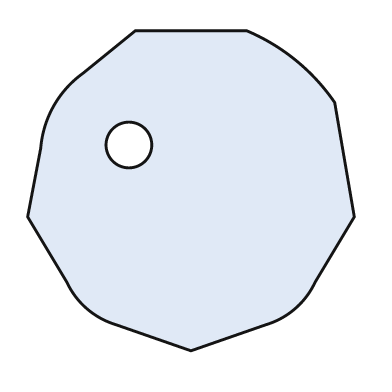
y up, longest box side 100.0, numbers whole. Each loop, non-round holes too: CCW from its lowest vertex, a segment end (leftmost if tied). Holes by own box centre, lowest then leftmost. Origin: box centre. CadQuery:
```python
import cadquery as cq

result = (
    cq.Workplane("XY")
    .moveTo(0.0, -49.0)
    .lineTo(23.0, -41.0)
    .threePointArc((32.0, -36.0), (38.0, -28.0))
    .lineTo(50.0, -8.0)
    .lineTo(44.0, 27.0)
    .threePointArc((32.0, 40.0), (17.0, 49.0))
    .lineTo(-17.0, 49.0)
    .lineTo(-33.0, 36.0)
    .threePointArc((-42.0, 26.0), (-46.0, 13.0))
    .lineTo(-50.0, -8.0)
    .lineTo(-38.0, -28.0)
    .threePointArc((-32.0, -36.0), (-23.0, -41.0))
    .close()
    .moveTo(-19.0, 14.0)
    .circle(7.0)
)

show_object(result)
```